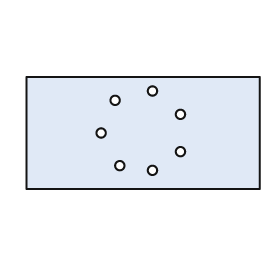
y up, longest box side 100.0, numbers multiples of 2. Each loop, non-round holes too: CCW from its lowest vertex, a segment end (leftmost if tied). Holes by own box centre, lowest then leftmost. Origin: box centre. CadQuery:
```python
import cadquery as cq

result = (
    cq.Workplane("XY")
    .moveTo(-50.0, -24.0)
    .lineTo(50.0, -24.0)
    .lineTo(50.0, 24.0)
    .lineTo(-50.0, 24.0)
    .close()
    .moveTo(4.0, -16.0)
    .circle(2.0)
    .moveTo(-10.0, -14.0)
    .circle(2.0)
    .moveTo(16.0, -8.0)
    .circle(2.0)
    .moveTo(-18.0, 0.0)
    .circle(2.0)
    .moveTo(16.0, 8.0)
    .circle(2.0)
    .moveTo(-12.0, 14.0)
    .circle(2.0)
    .moveTo(4.0, 18.0)
    .circle(2.0)
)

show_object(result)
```